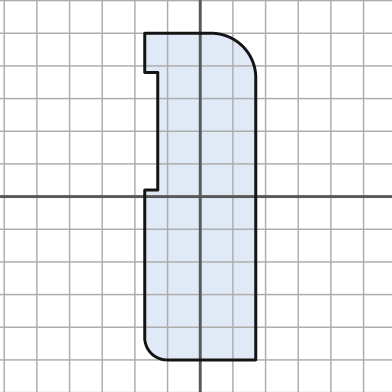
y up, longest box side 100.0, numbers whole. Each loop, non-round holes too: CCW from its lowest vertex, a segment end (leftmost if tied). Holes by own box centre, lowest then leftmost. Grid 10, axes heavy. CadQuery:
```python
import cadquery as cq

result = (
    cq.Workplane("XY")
    .moveTo(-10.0, -50.0)
    .lineTo(17.0, -50.0)
    .lineTo(17.0, 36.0)
    .threePointArc((13.0, 46.0), (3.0, 50.0))
    .lineTo(-17.0, 50.0)
    .lineTo(-17.0, 38.0)
    .lineTo(-13.0, 38.0)
    .lineTo(-13.0, 2.0)
    .lineTo(-17.0, 2.0)
    .lineTo(-17.0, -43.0)
    .threePointArc((-15.0, -48.0), (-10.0, -50.0))
    .close()
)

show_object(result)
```